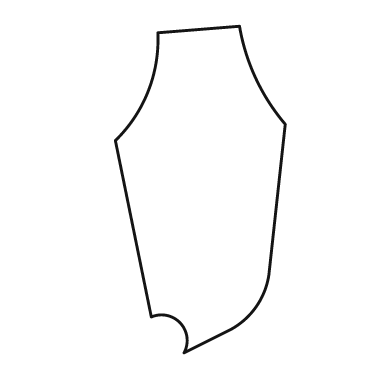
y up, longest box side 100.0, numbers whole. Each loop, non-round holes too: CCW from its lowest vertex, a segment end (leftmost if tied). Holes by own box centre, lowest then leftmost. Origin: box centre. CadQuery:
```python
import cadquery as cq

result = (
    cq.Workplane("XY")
    .moveTo(-5.0, -50.0)
    .lineTo(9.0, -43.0)
    .threePointArc((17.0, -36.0), (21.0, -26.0))
    .lineTo(26.0, 20.0)
    .threePointArc((17.0, 34.0), (12.0, 50.0))
    .lineTo(-13.0, 48.0)
    .threePointArc((-16.0, 30.0), (-26.0, 15.0))
    .lineTo(-15.0, -39.0)
    .threePointArc((-6.0, -41.0), (-5.0, -50.0))
    .close()
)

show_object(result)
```